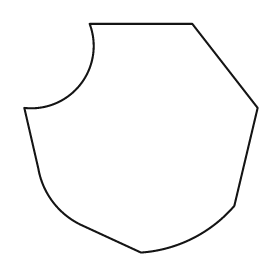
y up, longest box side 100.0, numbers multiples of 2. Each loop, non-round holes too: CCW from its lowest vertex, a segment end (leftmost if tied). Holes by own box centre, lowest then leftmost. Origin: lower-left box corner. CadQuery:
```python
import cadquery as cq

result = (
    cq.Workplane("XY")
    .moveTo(50.0, 0.0)
    .threePointArc((72.0, 6.0), (90.0, 20.0))
    .lineTo(100.0, 62.0)
    .lineTo(72.0, 98.0)
    .lineTo(28.0, 98.0)
    .threePointArc((24.0, 72.0), (0.0, 62.0))
    .lineTo(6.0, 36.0)
    .threePointArc((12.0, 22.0), (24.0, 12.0))
    .close()
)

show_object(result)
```